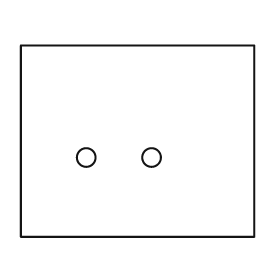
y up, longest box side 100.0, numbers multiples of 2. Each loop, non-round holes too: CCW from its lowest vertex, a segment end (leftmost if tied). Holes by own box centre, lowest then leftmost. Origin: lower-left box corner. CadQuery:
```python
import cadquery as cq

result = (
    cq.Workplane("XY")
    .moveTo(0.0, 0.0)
    .lineTo(100.0, 0.0)
    .lineTo(100.0, 82.0)
    .lineTo(0.0, 82.0)
    .close()
    .moveTo(28.0, 34.0)
    .circle(4.0)
    .moveTo(56.0, 34.0)
    .circle(4.0)
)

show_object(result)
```